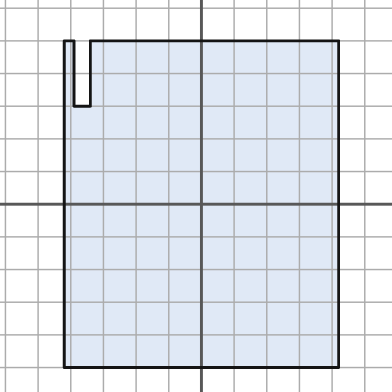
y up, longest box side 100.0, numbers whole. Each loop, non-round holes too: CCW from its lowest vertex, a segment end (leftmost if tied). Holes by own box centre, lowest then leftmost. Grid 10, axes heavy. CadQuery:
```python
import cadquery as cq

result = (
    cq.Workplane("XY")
    .moveTo(-42.0, -50.0)
    .lineTo(42.0, -50.0)
    .lineTo(42.0, 50.0)
    .lineTo(-34.0, 50.0)
    .lineTo(-34.0, 30.0)
    .lineTo(-39.0, 30.0)
    .lineTo(-39.0, 50.0)
    .lineTo(-42.0, 50.0)
    .close()
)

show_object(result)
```